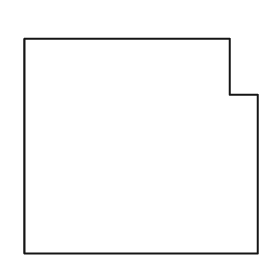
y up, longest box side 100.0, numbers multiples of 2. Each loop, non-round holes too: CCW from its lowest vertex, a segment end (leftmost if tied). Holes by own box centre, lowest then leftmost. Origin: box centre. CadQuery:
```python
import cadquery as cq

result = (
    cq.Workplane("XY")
    .moveTo(-50.0, -46.0)
    .lineTo(50.0, -46.0)
    .lineTo(50.0, 22.0)
    .lineTo(38.0, 22.0)
    .lineTo(38.0, 46.0)
    .lineTo(-50.0, 46.0)
    .close()
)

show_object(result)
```